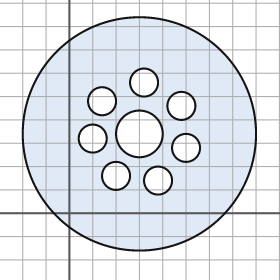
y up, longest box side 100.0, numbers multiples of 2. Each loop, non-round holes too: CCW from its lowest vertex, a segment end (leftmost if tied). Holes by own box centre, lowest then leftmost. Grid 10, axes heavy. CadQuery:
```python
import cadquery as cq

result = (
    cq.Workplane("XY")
    .moveTo(30.0, 34.0)
    .circle(50.0)
    .moveTo(38.0, 14.0)
    .circle(6.0)
    .moveTo(20.0, 16.0)
    .circle(6.0)
    .moveTo(50.0, 28.0)
    .circle(6.0)
    .moveTo(10.0, 32.0)
    .circle(6.0)
    .moveTo(30.0, 34.0)
    .circle(10.0)
    .moveTo(48.0, 46.0)
    .circle(6.0)
    .moveTo(14.0, 48.0)
    .circle(6.0)
    .moveTo(32.0, 56.0)
    .circle(6.0)
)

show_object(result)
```